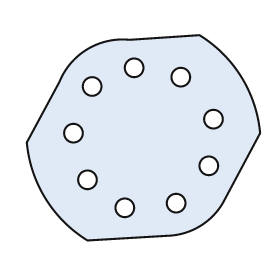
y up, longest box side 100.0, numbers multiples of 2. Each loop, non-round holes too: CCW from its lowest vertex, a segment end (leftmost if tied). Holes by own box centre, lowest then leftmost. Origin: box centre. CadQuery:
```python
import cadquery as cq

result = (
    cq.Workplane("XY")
    .moveTo(-24.0, -44.0)
    .lineTo(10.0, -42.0)
    .threePointArc((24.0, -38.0), (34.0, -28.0))
    .lineTo(50.0, 2.0)
    .threePointArc((42.0, 26.0), (24.0, 44.0))
    .lineTo(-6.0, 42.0)
    .threePointArc((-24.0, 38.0), (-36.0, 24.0))
    .lineTo(-50.0, -2.0)
    .threePointArc((-42.0, -26.0), (-24.0, -44.0))
    .close()
    .moveTo(-8.0, -30.0)
    .circle(4.0)
    .moveTo(14.0, -28.0)
    .circle(4.0)
    .moveTo(-24.0, -18.0)
    .circle(4.0)
    .moveTo(28.0, -12.0)
    .circle(4.0)
    .moveTo(-30.0, 2.0)
    .circle(4.0)
    .moveTo(30.0, 8.0)
    .circle(4.0)
    .moveTo(-22.0, 22.0)
    .circle(4.0)
    .moveTo(16.0, 26.0)
    .circle(4.0)
    .moveTo(-4.0, 30.0)
    .circle(4.0)
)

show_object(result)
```